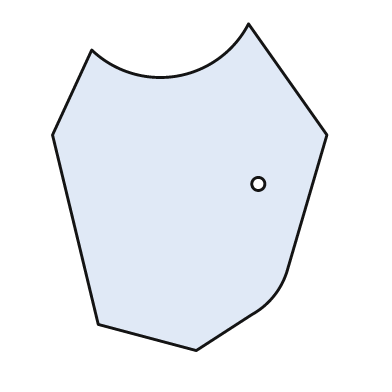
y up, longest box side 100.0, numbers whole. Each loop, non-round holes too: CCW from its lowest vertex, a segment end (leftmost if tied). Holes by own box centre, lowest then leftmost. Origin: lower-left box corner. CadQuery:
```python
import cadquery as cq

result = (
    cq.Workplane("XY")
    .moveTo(44.0, 0.0)
    .lineTo(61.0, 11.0)
    .threePointArc((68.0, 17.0), (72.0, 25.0))
    .lineTo(84.0, 66.0)
    .lineTo(60.0, 100.0)
    .threePointArc((38.0, 84.0), (12.0, 92.0))
    .lineTo(0.0, 66.0)
    .lineTo(14.0, 8.0)
    .close()
    .moveTo(63.0, 51.0)
    .circle(2.0)
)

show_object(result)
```